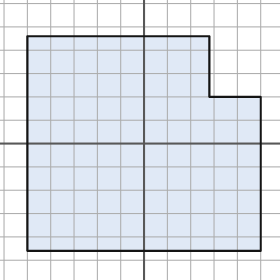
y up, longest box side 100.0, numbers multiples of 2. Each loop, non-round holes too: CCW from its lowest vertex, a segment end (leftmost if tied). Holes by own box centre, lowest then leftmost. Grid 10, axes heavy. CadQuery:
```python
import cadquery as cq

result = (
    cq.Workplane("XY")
    .moveTo(-50.0, -46.0)
    .lineTo(50.0, -46.0)
    .lineTo(50.0, 20.0)
    .lineTo(28.0, 20.0)
    .lineTo(28.0, 46.0)
    .lineTo(-50.0, 46.0)
    .close()
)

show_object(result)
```